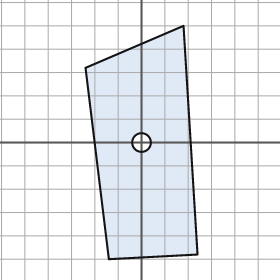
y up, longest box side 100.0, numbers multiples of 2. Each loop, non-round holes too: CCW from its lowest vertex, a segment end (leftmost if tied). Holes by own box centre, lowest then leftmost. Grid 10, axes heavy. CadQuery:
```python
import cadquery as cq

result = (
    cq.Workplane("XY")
    .moveTo(-14.0, -50.0)
    .lineTo(24.0, -48.0)
    .lineTo(18.0, 50.0)
    .lineTo(-24.0, 32.0)
    .close()
    .moveTo(0.0, 0.0)
    .circle(4.0)
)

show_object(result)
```